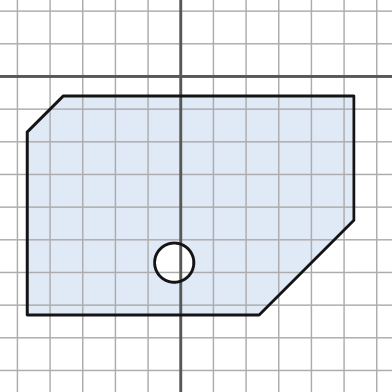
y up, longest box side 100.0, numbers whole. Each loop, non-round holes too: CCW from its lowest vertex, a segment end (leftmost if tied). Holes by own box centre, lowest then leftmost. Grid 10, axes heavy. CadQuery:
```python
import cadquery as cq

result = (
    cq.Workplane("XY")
    .moveTo(-47.0, -73.0)
    .lineTo(24.0, -73.0)
    .lineTo(53.0, -44.0)
    .lineTo(53.0, -6.0)
    .lineTo(-36.0, -6.0)
    .lineTo(-47.0, -17.0)
    .close()
    .moveTo(-2.0, -57.0)
    .circle(6.0)
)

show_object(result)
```